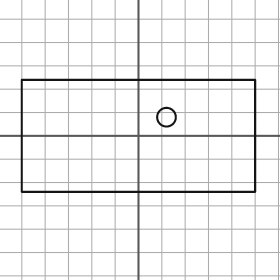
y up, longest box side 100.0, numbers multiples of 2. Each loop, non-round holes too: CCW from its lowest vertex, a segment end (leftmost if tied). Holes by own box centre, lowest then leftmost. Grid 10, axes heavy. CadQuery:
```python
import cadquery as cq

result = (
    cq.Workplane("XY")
    .moveTo(-50.0, -24.0)
    .lineTo(50.0, -24.0)
    .lineTo(50.0, 24.0)
    .lineTo(-50.0, 24.0)
    .close()
    .moveTo(12.0, 8.0)
    .circle(4.0)
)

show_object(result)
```